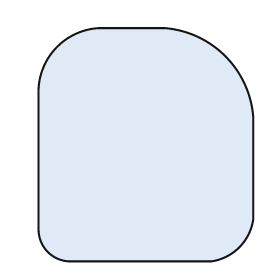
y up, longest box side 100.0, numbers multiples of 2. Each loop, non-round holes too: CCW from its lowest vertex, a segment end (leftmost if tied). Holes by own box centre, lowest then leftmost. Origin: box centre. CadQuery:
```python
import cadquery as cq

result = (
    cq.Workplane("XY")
    .moveTo(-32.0, -50.0)
    .lineTo(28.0, -50.0)
    .threePointArc((40.0, -44.0), (46.0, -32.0))
    .lineTo(46.0, 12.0)
    .threePointArc((34.0, 38.0), (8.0, 50.0))
    .lineTo(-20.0, 50.0)
    .threePointArc((-38.0, 42.0), (-46.0, 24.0))
    .lineTo(-46.0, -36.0)
    .threePointArc((-42.0, -46.0), (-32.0, -50.0))
    .close()
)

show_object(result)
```